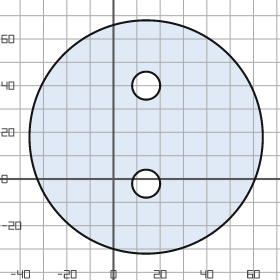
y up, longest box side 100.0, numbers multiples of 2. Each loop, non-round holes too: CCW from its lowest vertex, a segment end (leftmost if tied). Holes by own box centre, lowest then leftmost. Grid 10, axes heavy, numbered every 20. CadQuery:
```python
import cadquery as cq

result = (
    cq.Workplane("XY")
    .moveTo(14.0, 18.0)
    .circle(50.0)
    .moveTo(14.0, -2.0)
    .circle(6.0)
    .moveTo(14.0, 40.0)
    .circle(6.0)
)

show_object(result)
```